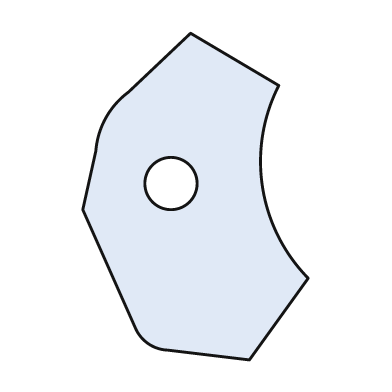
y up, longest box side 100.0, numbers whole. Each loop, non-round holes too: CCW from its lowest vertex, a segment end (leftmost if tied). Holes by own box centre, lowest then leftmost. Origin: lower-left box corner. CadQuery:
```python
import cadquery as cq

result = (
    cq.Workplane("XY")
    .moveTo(51.0, 0.0)
    .lineTo(69.0, 25.0)
    .threePointArc((55.0, 53.0), (60.0, 84.0))
    .lineTo(33.0, 100.0)
    .lineTo(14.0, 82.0)
    .threePointArc((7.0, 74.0), (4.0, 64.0))
    .lineTo(0.0, 46.0)
    .lineTo(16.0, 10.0)
    .threePointArc((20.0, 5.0), (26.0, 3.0))
    .close()
    .moveTo(27.0, 54.0)
    .circle(8.0)
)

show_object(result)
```